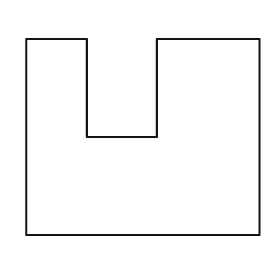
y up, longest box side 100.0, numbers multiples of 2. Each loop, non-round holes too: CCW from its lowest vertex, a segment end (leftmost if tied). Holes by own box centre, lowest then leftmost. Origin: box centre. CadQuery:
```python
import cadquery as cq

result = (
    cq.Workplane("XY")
    .moveTo(-50.0, -42.0)
    .lineTo(50.0, -42.0)
    .lineTo(50.0, 42.0)
    .lineTo(6.0, 42.0)
    .lineTo(6.0, 0.0)
    .lineTo(-24.0, 0.0)
    .lineTo(-24.0, 42.0)
    .lineTo(-50.0, 42.0)
    .close()
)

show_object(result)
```